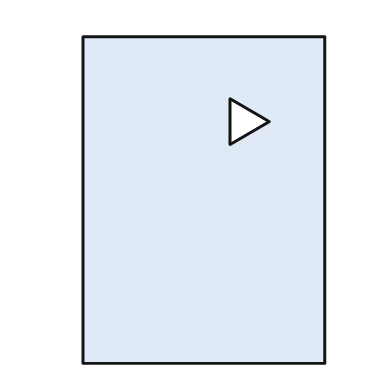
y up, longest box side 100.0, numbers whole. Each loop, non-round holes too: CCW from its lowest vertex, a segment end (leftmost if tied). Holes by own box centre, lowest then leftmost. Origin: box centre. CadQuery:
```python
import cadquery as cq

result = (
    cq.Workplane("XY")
    .moveTo(-37.0, -50.0)
    .lineTo(37.0, -50.0)
    .lineTo(37.0, 50.0)
    .lineTo(-37.0, 50.0)
    .close()
    .moveTo(8.0, 17.0)
    .lineTo(20.0, 24.0)
    .lineTo(8.0, 31.0)
    .close()
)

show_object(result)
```